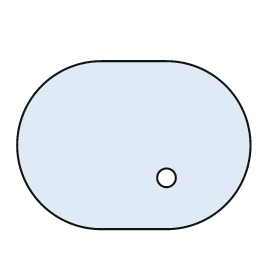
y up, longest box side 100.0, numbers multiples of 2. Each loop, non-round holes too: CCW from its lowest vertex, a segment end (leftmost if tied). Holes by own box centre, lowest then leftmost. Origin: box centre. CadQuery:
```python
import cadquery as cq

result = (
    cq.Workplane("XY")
    .moveTo(-14.0, -36.0)
    .lineTo(14.0, -36.0)
    .threePointArc((50.0, 0.0), (14.0, 36.0))
    .lineTo(-14.0, 36.0)
    .threePointArc((-50.0, 0.0), (-14.0, -36.0))
    .close()
    .moveTo(14.0, -14.0)
    .circle(4.0)
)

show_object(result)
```